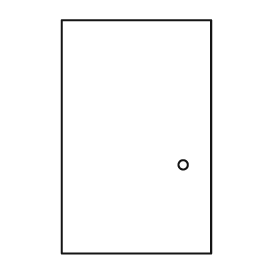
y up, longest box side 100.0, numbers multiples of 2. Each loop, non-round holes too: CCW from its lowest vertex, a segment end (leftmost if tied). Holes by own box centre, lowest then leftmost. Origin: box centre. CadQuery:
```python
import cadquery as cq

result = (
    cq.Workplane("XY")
    .moveTo(-32.0, -50.0)
    .lineTo(32.0, -50.0)
    .lineTo(32.0, 50.0)
    .lineTo(-32.0, 50.0)
    .close()
    .moveTo(20.0, -12.0)
    .circle(2.0)
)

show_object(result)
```